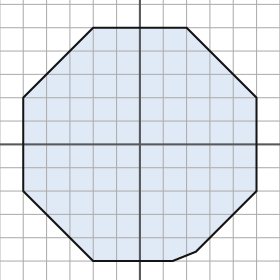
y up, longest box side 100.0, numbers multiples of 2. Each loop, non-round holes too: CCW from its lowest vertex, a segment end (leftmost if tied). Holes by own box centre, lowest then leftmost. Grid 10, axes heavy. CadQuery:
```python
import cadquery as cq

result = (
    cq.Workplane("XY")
    .moveTo(-20.0, -50.0)
    .lineTo(14.0, -50.0)
    .lineTo(24.0, -46.0)
    .lineTo(50.0, -20.0)
    .lineTo(50.0, 20.0)
    .lineTo(20.0, 50.0)
    .lineTo(-20.0, 50.0)
    .lineTo(-50.0, 20.0)
    .lineTo(-50.0, -20.0)
    .close()
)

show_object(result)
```